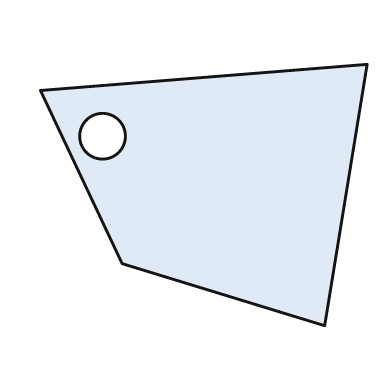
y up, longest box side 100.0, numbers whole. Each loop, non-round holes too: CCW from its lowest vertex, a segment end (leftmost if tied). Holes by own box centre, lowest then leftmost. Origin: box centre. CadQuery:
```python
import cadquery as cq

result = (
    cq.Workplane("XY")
    .moveTo(37.0, -40.0)
    .lineTo(50.0, 40.0)
    .lineTo(-50.0, 32.0)
    .lineTo(-25.0, -21.0)
    .close()
    .moveTo(-31.0, 18.0)
    .circle(7.0)
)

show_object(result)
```